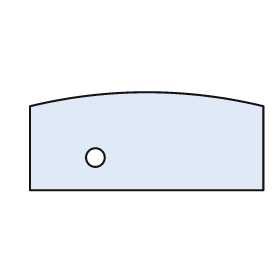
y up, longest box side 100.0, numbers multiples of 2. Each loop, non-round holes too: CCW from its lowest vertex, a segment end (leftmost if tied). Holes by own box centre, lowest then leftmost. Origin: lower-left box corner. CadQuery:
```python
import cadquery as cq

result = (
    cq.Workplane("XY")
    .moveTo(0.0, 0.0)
    .lineTo(100.0, 0.0)
    .lineTo(100.0, 36.0)
    .threePointArc((50.0, 42.0), (0.0, 36.0))
    .close()
    .moveTo(28.0, 14.0)
    .circle(4.0)
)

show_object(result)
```